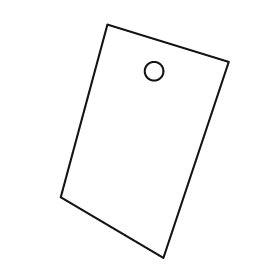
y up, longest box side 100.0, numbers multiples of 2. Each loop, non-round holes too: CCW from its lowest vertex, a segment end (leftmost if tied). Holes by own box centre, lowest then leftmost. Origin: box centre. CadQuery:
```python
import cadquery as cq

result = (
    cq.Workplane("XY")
    .moveTo(8.0, -50.0)
    .lineTo(36.0, 34.0)
    .lineTo(-16.0, 50.0)
    .lineTo(-36.0, -24.0)
    .close()
    .moveTo(4.0, 30.0)
    .circle(4.0)
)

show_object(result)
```